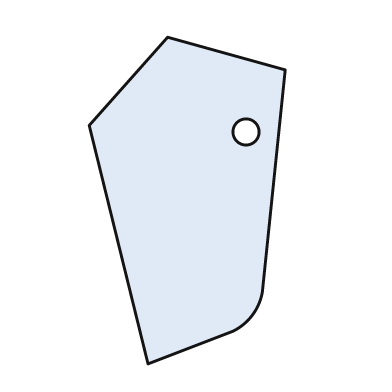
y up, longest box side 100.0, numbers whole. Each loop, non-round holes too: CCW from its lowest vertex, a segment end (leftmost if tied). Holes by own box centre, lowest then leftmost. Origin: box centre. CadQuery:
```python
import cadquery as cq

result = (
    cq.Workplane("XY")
    .moveTo(-12.0, -50.0)
    .lineTo(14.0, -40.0)
    .threePointArc((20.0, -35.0), (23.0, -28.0))
    .lineTo(30.0, 40.0)
    .lineTo(-6.0, 50.0)
    .lineTo(-30.0, 23.0)
    .close()
    .moveTo(18.0, 21.0)
    .circle(4.0)
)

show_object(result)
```